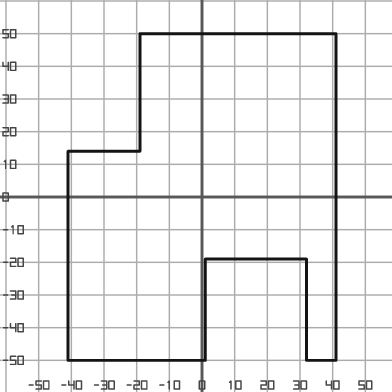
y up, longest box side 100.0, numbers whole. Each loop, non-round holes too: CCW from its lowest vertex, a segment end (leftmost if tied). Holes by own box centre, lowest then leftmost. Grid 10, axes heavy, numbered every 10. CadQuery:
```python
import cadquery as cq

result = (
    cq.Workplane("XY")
    .moveTo(-41.0, -50.0)
    .lineTo(1.0, -50.0)
    .lineTo(1.0, -19.0)
    .lineTo(32.0, -19.0)
    .lineTo(32.0, -50.0)
    .lineTo(41.0, -50.0)
    .lineTo(41.0, 50.0)
    .lineTo(-19.0, 50.0)
    .lineTo(-19.0, 14.0)
    .lineTo(-41.0, 14.0)
    .close()
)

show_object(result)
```